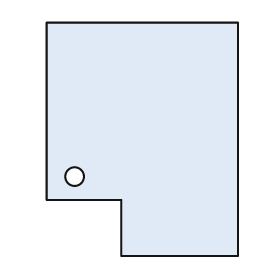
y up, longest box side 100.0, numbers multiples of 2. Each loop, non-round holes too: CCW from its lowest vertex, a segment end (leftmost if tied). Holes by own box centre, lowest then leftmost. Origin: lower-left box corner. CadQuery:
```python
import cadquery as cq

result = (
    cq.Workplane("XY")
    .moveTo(32.0, 0.0)
    .lineTo(82.0, 0.0)
    .lineTo(82.0, 100.0)
    .lineTo(0.0, 100.0)
    .lineTo(0.0, 24.0)
    .lineTo(32.0, 24.0)
    .close()
    .moveTo(12.0, 34.0)
    .circle(4.0)
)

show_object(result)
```